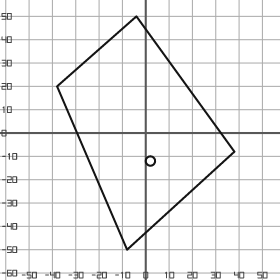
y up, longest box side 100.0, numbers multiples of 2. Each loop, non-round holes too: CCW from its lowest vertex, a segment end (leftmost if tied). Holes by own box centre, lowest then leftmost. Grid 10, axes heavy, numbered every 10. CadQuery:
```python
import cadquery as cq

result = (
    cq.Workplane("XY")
    .moveTo(-8.0, -50.0)
    .lineTo(38.0, -8.0)
    .lineTo(-4.0, 50.0)
    .lineTo(-38.0, 20.0)
    .close()
    .moveTo(2.0, -12.0)
    .circle(2.0)
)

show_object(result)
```